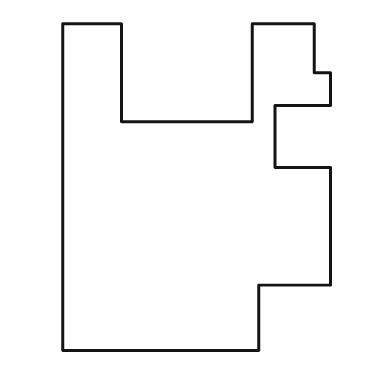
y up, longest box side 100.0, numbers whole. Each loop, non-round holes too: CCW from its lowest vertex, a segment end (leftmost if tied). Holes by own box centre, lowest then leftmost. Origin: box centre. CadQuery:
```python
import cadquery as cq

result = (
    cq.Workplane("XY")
    .moveTo(-41.0, -50.0)
    .lineTo(19.0, -50.0)
    .lineTo(19.0, -30.0)
    .lineTo(41.0, -30.0)
    .lineTo(41.0, 6.0)
    .lineTo(24.0, 6.0)
    .lineTo(24.0, 25.0)
    .lineTo(41.0, 25.0)
    .lineTo(41.0, 35.0)
    .lineTo(36.0, 35.0)
    .lineTo(36.0, 50.0)
    .lineTo(17.0, 50.0)
    .lineTo(17.0, 20.0)
    .lineTo(-23.0, 20.0)
    .lineTo(-23.0, 50.0)
    .lineTo(-41.0, 50.0)
    .close()
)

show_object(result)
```